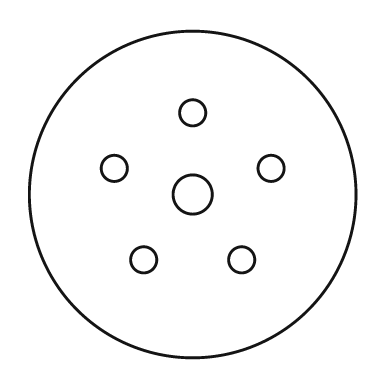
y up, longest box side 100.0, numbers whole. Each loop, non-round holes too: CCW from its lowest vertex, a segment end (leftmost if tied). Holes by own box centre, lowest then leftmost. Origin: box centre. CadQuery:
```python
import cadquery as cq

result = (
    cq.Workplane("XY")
    .moveTo(0.0, 0.0)
    .circle(50.0)
    .moveTo(-15.0, -20.0)
    .circle(4.0)
    .moveTo(15.0, -20.0)
    .circle(4.0)
    .moveTo(0.0, 0.0)
    .circle(6.0)
    .moveTo(-24.0, 8.0)
    .circle(4.0)
    .moveTo(24.0, 8.0)
    .circle(4.0)
    .moveTo(0.0, 25.0)
    .circle(4.0)
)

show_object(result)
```